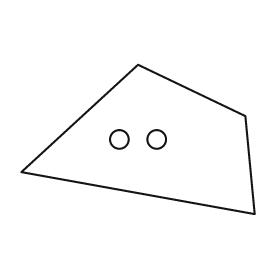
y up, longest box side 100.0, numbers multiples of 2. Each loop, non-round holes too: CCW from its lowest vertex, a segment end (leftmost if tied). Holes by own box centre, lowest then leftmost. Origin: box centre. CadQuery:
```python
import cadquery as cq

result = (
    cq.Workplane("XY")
    .moveTo(50.0, -32.0)
    .lineTo(46.0, 10.0)
    .lineTo(0.0, 32.0)
    .lineTo(-50.0, -14.0)
    .close()
    .moveTo(-8.0, 0.0)
    .circle(4.0)
    .moveTo(8.0, 0.0)
    .circle(4.0)
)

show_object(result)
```